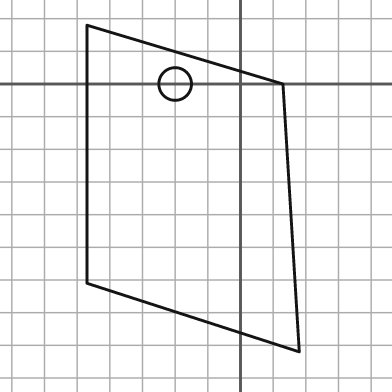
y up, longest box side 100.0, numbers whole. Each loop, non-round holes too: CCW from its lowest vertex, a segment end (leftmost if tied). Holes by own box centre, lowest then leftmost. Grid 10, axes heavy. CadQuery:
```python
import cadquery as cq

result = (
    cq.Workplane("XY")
    .moveTo(18.0, -82.0)
    .lineTo(13.0, 0.0)
    .lineTo(-47.0, 18.0)
    .lineTo(-47.0, -61.0)
    .close()
    .moveTo(-20.0, 0.0)
    .circle(5.0)
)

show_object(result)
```